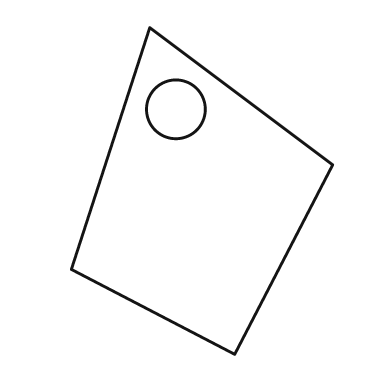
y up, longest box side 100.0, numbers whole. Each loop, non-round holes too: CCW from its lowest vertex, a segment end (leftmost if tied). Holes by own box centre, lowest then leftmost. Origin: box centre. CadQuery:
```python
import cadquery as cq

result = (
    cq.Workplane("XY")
    .moveTo(10.0, -50.0)
    .lineTo(40.0, 8.0)
    .lineTo(-16.0, 50.0)
    .lineTo(-40.0, -24.0)
    .close()
    .moveTo(-8.0, 25.0)
    .circle(9.0)
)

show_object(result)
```